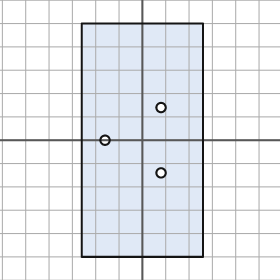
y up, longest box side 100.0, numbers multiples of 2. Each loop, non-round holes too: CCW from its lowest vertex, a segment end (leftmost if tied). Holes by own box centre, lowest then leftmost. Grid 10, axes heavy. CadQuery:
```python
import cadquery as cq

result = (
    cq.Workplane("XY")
    .moveTo(-26.0, -50.0)
    .lineTo(26.0, -50.0)
    .lineTo(26.0, 50.0)
    .lineTo(-26.0, 50.0)
    .close()
    .moveTo(8.0, -14.0)
    .circle(2.0)
    .moveTo(-16.0, 0.0)
    .circle(2.0)
    .moveTo(8.0, 14.0)
    .circle(2.0)
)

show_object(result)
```